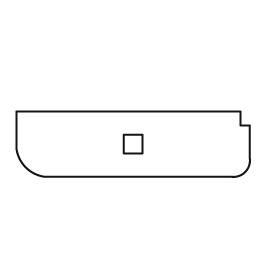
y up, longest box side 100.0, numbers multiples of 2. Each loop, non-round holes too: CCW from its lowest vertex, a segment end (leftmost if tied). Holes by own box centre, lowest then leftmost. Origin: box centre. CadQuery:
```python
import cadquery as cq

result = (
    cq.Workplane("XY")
    .moveTo(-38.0, -14.0)
    .lineTo(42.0, -14.0)
    .threePointArc((48.0, -12.0), (50.0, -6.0))
    .lineTo(50.0, 8.0)
    .lineTo(46.0, 8.0)
    .lineTo(46.0, 14.0)
    .lineTo(-50.0, 14.0)
    .lineTo(-50.0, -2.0)
    .threePointArc((-46.0, -10.0), (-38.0, -14.0))
    .close()
    .moveTo(-4.0, -4.0)
    .lineTo(4.0, -4.0)
    .lineTo(4.0, 4.0)
    .lineTo(-4.0, 4.0)
    .close()
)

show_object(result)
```